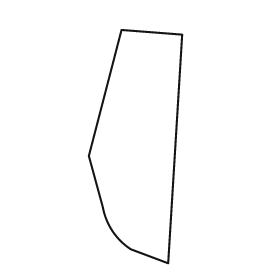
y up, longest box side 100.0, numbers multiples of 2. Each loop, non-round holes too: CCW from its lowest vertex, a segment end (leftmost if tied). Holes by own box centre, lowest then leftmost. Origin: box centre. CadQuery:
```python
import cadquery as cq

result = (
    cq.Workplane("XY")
    .moveTo(14.0, -50.0)
    .lineTo(20.0, 48.0)
    .lineTo(-6.0, 50.0)
    .lineTo(-20.0, -4.0)
    .lineTo(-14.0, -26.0)
    .threePointArc((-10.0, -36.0), (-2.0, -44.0))
    .close()
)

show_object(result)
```